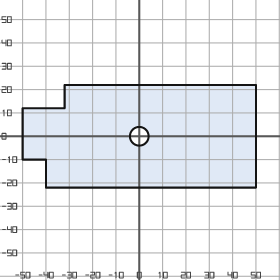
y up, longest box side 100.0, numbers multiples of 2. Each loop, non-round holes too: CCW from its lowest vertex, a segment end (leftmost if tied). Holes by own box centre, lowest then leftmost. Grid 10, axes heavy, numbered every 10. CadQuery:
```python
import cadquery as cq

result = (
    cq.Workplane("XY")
    .moveTo(-40.0, -22.0)
    .lineTo(50.0, -22.0)
    .lineTo(50.0, 22.0)
    .lineTo(-32.0, 22.0)
    .lineTo(-32.0, 12.0)
    .lineTo(-50.0, 12.0)
    .lineTo(-50.0, -10.0)
    .lineTo(-40.0, -10.0)
    .close()
    .moveTo(0.0, 0.0)
    .circle(4.0)
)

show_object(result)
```